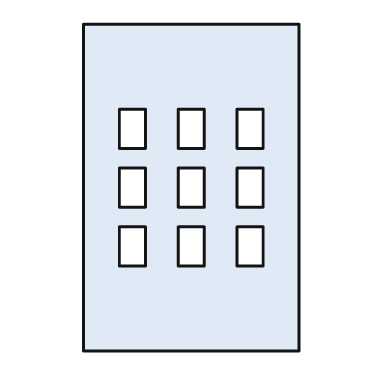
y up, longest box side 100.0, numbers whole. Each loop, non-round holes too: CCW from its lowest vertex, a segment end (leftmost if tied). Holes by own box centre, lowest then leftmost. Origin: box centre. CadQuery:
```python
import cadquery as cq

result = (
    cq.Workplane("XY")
    .moveTo(-33.0, -50.0)
    .lineTo(33.0, -50.0)
    .lineTo(33.0, 50.0)
    .lineTo(-33.0, 50.0)
    .close()
    .moveTo(-22.0, -24.0)
    .lineTo(-14.0, -24.0)
    .lineTo(-14.0, -12.0)
    .lineTo(-22.0, -12.0)
    .close()
    .moveTo(-4.0, -24.0)
    .lineTo(4.0, -24.0)
    .lineTo(4.0, -12.0)
    .lineTo(-4.0, -12.0)
    .close()
    .moveTo(14.0, -24.0)
    .lineTo(22.0, -24.0)
    .lineTo(22.0, -12.0)
    .lineTo(14.0, -12.0)
    .close()
    .moveTo(-22.0, -6.0)
    .lineTo(-14.0, -6.0)
    .lineTo(-14.0, 6.0)
    .lineTo(-22.0, 6.0)
    .close()
    .moveTo(-4.0, -6.0)
    .lineTo(4.0, -6.0)
    .lineTo(4.0, 6.0)
    .lineTo(-4.0, 6.0)
    .close()
    .moveTo(14.0, -6.0)
    .lineTo(22.0, -6.0)
    .lineTo(22.0, 6.0)
    .lineTo(14.0, 6.0)
    .close()
    .moveTo(-22.0, 12.0)
    .lineTo(-14.0, 12.0)
    .lineTo(-14.0, 24.0)
    .lineTo(-22.0, 24.0)
    .close()
    .moveTo(-4.0, 12.0)
    .lineTo(4.0, 12.0)
    .lineTo(4.0, 24.0)
    .lineTo(-4.0, 24.0)
    .close()
    .moveTo(14.0, 12.0)
    .lineTo(22.0, 12.0)
    .lineTo(22.0, 24.0)
    .lineTo(14.0, 24.0)
    .close()
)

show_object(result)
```